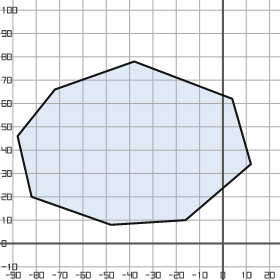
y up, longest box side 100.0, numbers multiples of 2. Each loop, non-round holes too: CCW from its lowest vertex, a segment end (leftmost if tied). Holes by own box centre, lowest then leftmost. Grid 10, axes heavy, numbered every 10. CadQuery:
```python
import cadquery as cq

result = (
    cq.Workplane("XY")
    .moveTo(-48.0, 8.0)
    .lineTo(-16.0, 10.0)
    .lineTo(12.0, 34.0)
    .lineTo(4.0, 62.0)
    .lineTo(-38.0, 78.0)
    .lineTo(-72.0, 66.0)
    .lineTo(-88.0, 46.0)
    .lineTo(-82.0, 20.0)
    .close()
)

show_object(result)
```